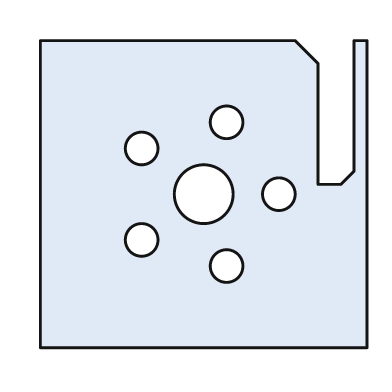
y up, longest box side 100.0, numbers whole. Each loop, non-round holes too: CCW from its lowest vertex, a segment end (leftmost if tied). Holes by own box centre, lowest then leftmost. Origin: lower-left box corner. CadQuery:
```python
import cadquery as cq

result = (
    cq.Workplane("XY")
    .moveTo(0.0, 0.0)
    .lineTo(100.0, 0.0)
    .lineTo(100.0, 94.0)
    .lineTo(96.0, 94.0)
    .lineTo(96.0, 54.0)
    .lineTo(92.0, 50.0)
    .lineTo(85.0, 50.0)
    .lineTo(85.0, 87.0)
    .lineTo(78.0, 94.0)
    .lineTo(0.0, 94.0)
    .close()
    .moveTo(57.0, 25.0)
    .circle(5.0)
    .moveTo(31.0, 33.0)
    .circle(5.0)
    .moveTo(50.0, 47.0)
    .circle(9.0)
    .moveTo(73.0, 47.0)
    .circle(5.0)
    .moveTo(31.0, 61.0)
    .circle(5.0)
    .moveTo(57.0, 69.0)
    .circle(5.0)
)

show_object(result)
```